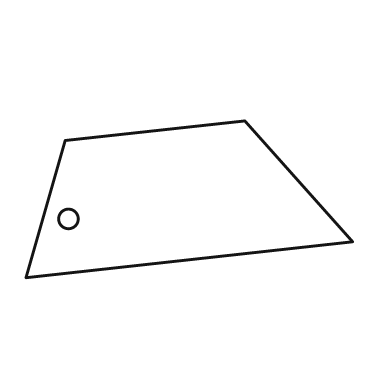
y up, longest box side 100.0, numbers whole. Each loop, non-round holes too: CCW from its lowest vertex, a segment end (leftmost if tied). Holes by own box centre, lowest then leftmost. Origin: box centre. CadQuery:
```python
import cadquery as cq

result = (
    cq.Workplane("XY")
    .moveTo(-50.0, -24.0)
    .lineTo(50.0, -13.0)
    .lineTo(17.0, 24.0)
    .lineTo(-38.0, 18.0)
    .close()
    .moveTo(-37.0, -6.0)
    .circle(3.0)
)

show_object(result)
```